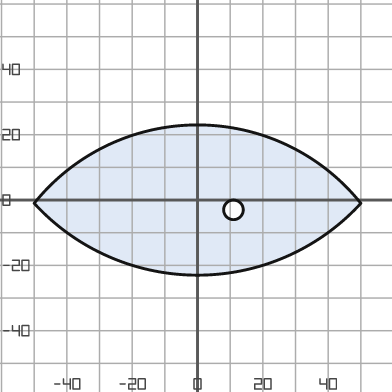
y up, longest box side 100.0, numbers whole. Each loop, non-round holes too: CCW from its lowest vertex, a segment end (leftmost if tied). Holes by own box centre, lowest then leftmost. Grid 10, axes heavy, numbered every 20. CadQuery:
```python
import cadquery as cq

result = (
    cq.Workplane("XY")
    .moveTo(-50.0, -1.0)
    .threePointArc((0.0, -23.0), (50.0, -1.0))
    .threePointArc((0.0, 23.0), (-50.0, -1.0))
    .close()
    .moveTo(11.0, -3.0)
    .circle(3.0)
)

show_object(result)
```